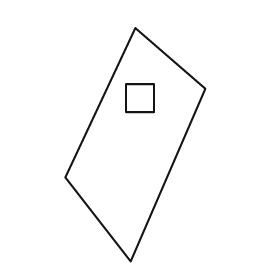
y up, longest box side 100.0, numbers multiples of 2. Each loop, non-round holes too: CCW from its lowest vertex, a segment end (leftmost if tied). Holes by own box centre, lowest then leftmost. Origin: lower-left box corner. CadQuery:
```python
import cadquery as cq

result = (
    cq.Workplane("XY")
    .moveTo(28.0, 0.0)
    .lineTo(60.0, 74.0)
    .lineTo(30.0, 100.0)
    .lineTo(0.0, 36.0)
    .close()
    .moveTo(26.0, 64.0)
    .lineTo(38.0, 64.0)
    .lineTo(38.0, 76.0)
    .lineTo(26.0, 76.0)
    .close()
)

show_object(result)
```